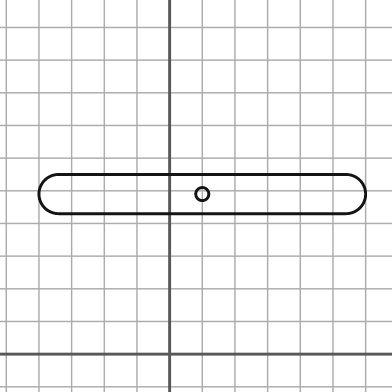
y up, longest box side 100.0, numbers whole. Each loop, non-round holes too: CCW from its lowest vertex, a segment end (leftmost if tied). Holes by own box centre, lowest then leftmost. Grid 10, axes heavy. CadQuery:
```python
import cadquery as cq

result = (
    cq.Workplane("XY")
    .moveTo(-34.0, 43.0)
    .lineTo(54.0, 43.0)
    .threePointArc((60.0, 49.0), (54.0, 55.0))
    .lineTo(-34.0, 55.0)
    .threePointArc((-40.0, 49.0), (-34.0, 43.0))
    .close()
    .moveTo(10.0, 49.0)
    .circle(2.0)
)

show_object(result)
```